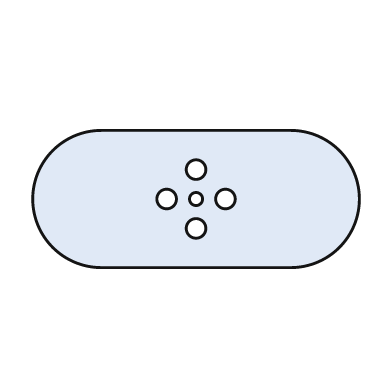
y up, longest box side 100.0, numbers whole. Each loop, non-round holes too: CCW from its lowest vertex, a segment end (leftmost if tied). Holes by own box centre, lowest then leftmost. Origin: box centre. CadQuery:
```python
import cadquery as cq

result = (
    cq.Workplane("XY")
    .moveTo(-29.0, -21.0)
    .lineTo(29.0, -21.0)
    .threePointArc((50.0, 0.0), (29.0, 21.0))
    .lineTo(-29.0, 21.0)
    .threePointArc((-50.0, 0.0), (-29.0, -21.0))
    .close()
    .moveTo(0.0, -9.0)
    .circle(3.0)
    .moveTo(-9.0, 0.0)
    .circle(3.0)
    .moveTo(0.0, 0.0)
    .circle(2.0)
    .moveTo(9.0, 0.0)
    .circle(3.0)
    .moveTo(0.0, 9.0)
    .circle(3.0)
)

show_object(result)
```